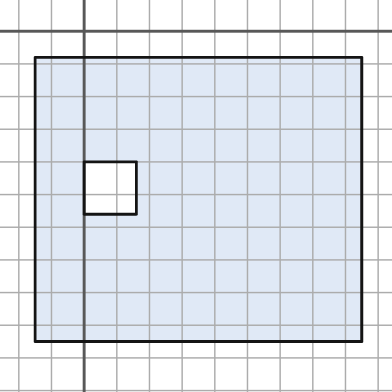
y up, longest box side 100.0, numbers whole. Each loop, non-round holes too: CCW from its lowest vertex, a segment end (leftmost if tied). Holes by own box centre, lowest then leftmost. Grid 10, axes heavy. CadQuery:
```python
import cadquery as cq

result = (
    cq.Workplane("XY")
    .moveTo(-15.0, -95.0)
    .lineTo(85.0, -95.0)
    .lineTo(85.0, -8.0)
    .lineTo(-15.0, -8.0)
    .close()
    .moveTo(0.0, -56.0)
    .lineTo(16.0, -56.0)
    .lineTo(16.0, -40.0)
    .lineTo(0.0, -40.0)
    .close()
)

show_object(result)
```